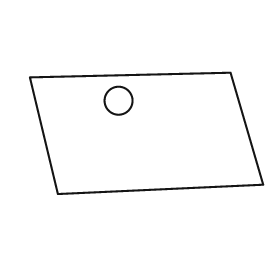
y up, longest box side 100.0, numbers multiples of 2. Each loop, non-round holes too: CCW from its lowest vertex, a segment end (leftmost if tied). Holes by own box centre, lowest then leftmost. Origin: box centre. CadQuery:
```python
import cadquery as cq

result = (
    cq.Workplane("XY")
    .moveTo(-38.0, -26.0)
    .lineTo(50.0, -22.0)
    .lineTo(36.0, 26.0)
    .lineTo(-50.0, 24.0)
    .close()
    .moveTo(-12.0, 14.0)
    .circle(6.0)
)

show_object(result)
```